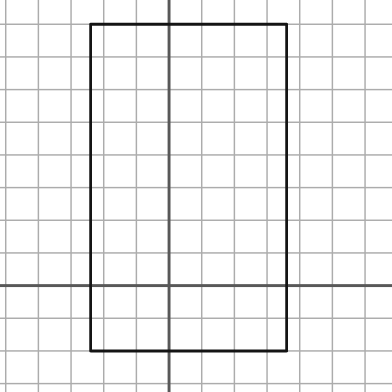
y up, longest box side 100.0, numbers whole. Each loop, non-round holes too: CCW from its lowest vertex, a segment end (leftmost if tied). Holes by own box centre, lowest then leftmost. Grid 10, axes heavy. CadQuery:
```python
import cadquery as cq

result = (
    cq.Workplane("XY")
    .moveTo(-24.0, -20.0)
    .lineTo(36.0, -20.0)
    .lineTo(36.0, 80.0)
    .lineTo(-24.0, 80.0)
    .close()
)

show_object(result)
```